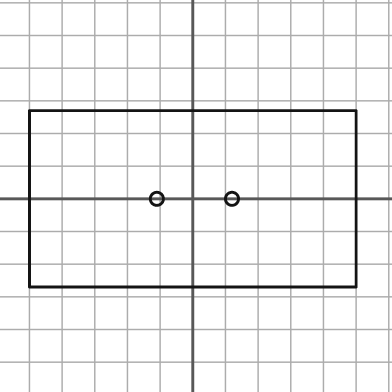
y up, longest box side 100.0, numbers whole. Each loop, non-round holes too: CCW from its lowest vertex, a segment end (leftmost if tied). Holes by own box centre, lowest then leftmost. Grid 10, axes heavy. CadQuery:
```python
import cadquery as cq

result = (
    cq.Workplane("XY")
    .moveTo(-50.0, -27.0)
    .lineTo(50.0, -27.0)
    .lineTo(50.0, 27.0)
    .lineTo(-50.0, 27.0)
    .close()
    .moveTo(-11.0, 0.0)
    .circle(2.0)
    .moveTo(12.0, 0.0)
    .circle(2.0)
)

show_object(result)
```